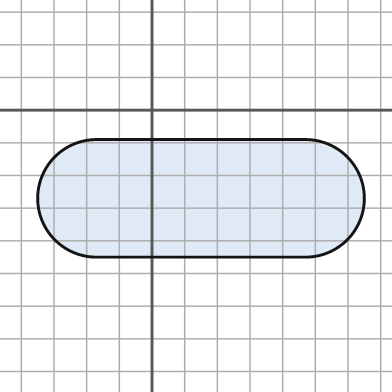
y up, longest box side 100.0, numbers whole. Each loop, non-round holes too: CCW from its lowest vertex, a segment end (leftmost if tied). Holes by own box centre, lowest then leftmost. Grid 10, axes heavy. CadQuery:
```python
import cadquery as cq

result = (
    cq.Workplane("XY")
    .moveTo(-17.0, -45.0)
    .lineTo(47.0, -45.0)
    .threePointArc((65.0, -27.0), (47.0, -9.0))
    .lineTo(-17.0, -9.0)
    .threePointArc((-35.0, -27.0), (-17.0, -45.0))
    .close()
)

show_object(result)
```